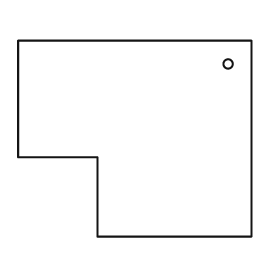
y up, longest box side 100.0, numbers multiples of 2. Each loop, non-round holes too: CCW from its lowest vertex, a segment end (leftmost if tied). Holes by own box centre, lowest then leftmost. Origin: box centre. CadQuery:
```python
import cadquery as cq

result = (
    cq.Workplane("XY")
    .moveTo(-16.0, -42.0)
    .lineTo(50.0, -42.0)
    .lineTo(50.0, 42.0)
    .lineTo(-50.0, 42.0)
    .lineTo(-50.0, -8.0)
    .lineTo(-16.0, -8.0)
    .close()
    .moveTo(40.0, 32.0)
    .circle(2.0)
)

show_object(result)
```